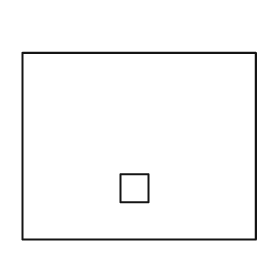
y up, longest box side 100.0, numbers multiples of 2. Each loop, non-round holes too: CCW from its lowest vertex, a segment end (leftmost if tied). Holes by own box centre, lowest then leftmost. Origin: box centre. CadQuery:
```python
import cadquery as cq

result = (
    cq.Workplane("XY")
    .moveTo(-50.0, -40.0)
    .lineTo(50.0, -40.0)
    .lineTo(50.0, 40.0)
    .lineTo(-50.0, 40.0)
    .close()
    .moveTo(-8.0, -24.0)
    .lineTo(4.0, -24.0)
    .lineTo(4.0, -12.0)
    .lineTo(-8.0, -12.0)
    .close()
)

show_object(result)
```